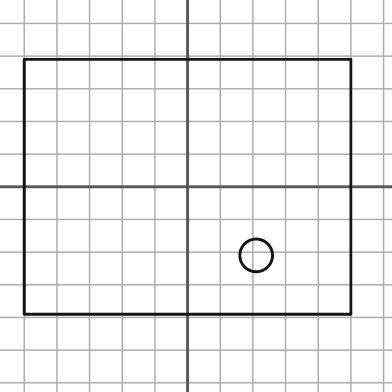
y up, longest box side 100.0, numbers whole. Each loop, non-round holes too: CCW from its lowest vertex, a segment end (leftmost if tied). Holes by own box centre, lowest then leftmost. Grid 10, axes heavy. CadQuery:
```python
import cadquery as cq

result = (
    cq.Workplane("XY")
    .moveTo(-50.0, -39.0)
    .lineTo(50.0, -39.0)
    .lineTo(50.0, 39.0)
    .lineTo(-50.0, 39.0)
    .close()
    .moveTo(21.0, -21.0)
    .circle(5.0)
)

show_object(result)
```